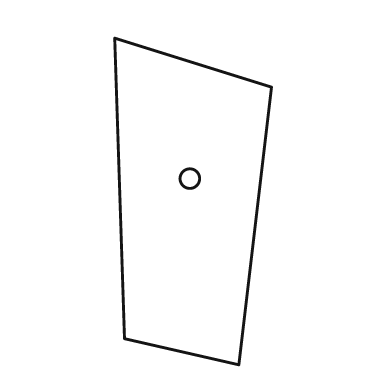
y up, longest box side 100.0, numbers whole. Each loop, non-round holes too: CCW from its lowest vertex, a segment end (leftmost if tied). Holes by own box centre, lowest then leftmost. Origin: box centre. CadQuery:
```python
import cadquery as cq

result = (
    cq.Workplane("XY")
    .moveTo(14.0, -50.0)
    .lineTo(24.0, 35.0)
    .lineTo(-24.0, 50.0)
    .lineTo(-21.0, -42.0)
    .close()
    .moveTo(-1.0, 7.0)
    .circle(3.0)
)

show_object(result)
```